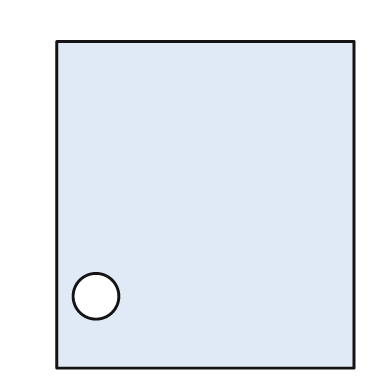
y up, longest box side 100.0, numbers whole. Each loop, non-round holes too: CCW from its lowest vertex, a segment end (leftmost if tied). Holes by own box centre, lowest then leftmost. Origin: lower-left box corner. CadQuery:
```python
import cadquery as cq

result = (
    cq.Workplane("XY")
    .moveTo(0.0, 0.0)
    .lineTo(91.0, 0.0)
    .lineTo(91.0, 100.0)
    .lineTo(0.0, 100.0)
    .close()
    .moveTo(12.0, 22.0)
    .circle(7.0)
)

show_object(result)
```